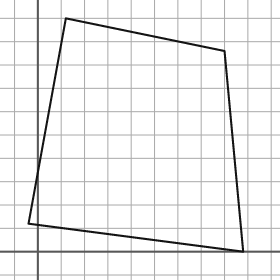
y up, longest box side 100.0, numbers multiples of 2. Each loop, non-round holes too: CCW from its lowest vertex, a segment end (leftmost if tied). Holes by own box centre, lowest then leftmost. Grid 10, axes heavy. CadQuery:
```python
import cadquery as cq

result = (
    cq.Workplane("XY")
    .moveTo(88.0, 0.0)
    .lineTo(80.0, 86.0)
    .lineTo(12.0, 100.0)
    .lineTo(-4.0, 12.0)
    .close()
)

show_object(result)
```